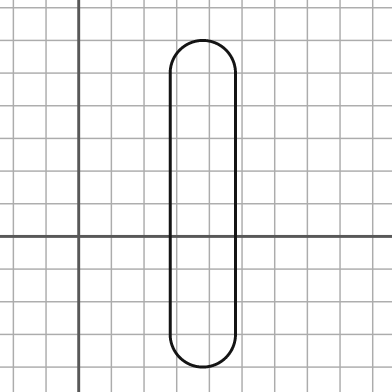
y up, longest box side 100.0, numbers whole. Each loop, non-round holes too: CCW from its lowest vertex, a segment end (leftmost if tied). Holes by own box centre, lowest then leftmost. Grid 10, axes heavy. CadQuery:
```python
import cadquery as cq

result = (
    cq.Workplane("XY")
    .moveTo(28.0, -30.0)
    .threePointArc((38.0, -40.0), (48.0, -30.0))
    .lineTo(48.0, 50.0)
    .threePointArc((38.0, 60.0), (28.0, 50.0))
    .close()
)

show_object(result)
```